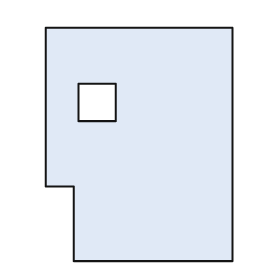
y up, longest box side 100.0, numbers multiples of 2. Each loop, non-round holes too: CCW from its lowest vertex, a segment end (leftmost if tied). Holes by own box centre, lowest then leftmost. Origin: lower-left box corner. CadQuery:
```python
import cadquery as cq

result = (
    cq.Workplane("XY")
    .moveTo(12.0, 0.0)
    .lineTo(80.0, 0.0)
    .lineTo(80.0, 100.0)
    .lineTo(0.0, 100.0)
    .lineTo(0.0, 32.0)
    .lineTo(12.0, 32.0)
    .close()
    .moveTo(14.0, 60.0)
    .lineTo(30.0, 60.0)
    .lineTo(30.0, 76.0)
    .lineTo(14.0, 76.0)
    .close()
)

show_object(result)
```